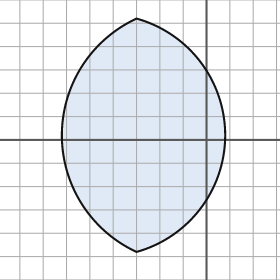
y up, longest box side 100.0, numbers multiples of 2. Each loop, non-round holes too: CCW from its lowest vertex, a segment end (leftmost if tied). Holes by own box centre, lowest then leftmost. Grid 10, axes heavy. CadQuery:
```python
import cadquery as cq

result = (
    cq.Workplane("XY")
    .moveTo(-30.0, -48.0)
    .threePointArc((8.0, 2.0), (-30.0, 52.0))
    .threePointArc((-62.0, 2.0), (-30.0, -48.0))
    .close()
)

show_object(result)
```